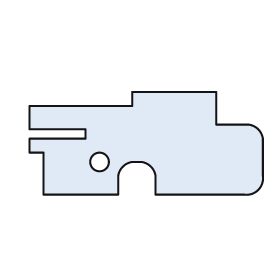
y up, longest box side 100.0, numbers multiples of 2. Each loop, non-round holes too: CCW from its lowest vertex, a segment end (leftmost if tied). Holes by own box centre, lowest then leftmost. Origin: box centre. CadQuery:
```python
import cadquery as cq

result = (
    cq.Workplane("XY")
    .moveTo(-44.0, -22.0)
    .lineTo(-12.0, -22.0)
    .lineTo(-12.0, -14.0)
    .threePointArc((-10.0, -10.0), (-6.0, -8.0))
    .lineTo(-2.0, -8.0)
    .threePointArc((2.0, -10.0), (4.0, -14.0))
    .lineTo(4.0, -22.0)
    .lineTo(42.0, -22.0)
    .threePointArc((48.0, -20.0), (50.0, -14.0))
    .lineTo(50.0, 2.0)
    .threePointArc((48.0, 6.0), (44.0, 8.0))
    .lineTo(30.0, 8.0)
    .lineTo(30.0, 22.0)
    .lineTo(-6.0, 22.0)
    .lineTo(-6.0, 16.0)
    .lineTo(-50.0, 16.0)
    .lineTo(-50.0, 6.0)
    .lineTo(-26.0, 6.0)
    .lineTo(-26.0, 2.0)
    .lineTo(-50.0, 2.0)
    .lineTo(-50.0, -4.0)
    .lineTo(-44.0, -4.0)
    .close()
    .moveTo(-20.0, -8.0)
    .circle(4.0)
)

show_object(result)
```